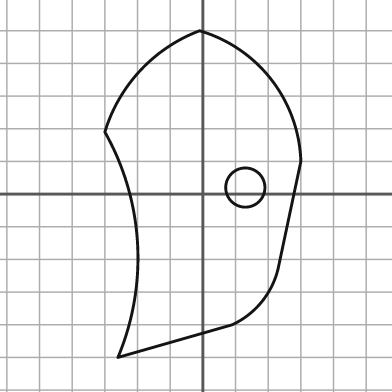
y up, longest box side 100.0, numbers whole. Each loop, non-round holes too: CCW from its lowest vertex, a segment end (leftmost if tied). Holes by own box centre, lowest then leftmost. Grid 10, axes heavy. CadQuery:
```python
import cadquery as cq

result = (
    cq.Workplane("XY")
    .moveTo(-26.0, -50.0)
    .lineTo(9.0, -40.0)
    .threePointArc((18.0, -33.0), (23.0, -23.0))
    .lineTo(30.0, 10.0)
    .threePointArc((21.0, 35.0), (-1.0, 50.0))
    .threePointArc((-19.0, 38.0), (-30.0, 19.0))
    .threePointArc((-20.0, -15.0), (-26.0, -50.0))
    .close()
    .moveTo(13.0, 2.0)
    .circle(6.0)
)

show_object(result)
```